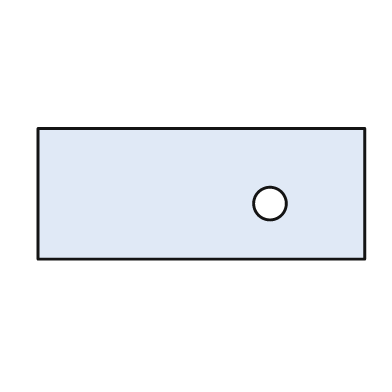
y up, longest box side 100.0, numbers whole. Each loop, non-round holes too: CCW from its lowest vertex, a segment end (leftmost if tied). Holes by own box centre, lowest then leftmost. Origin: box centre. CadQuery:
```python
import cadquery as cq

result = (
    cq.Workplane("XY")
    .moveTo(-50.0, -20.0)
    .lineTo(50.0, -20.0)
    .lineTo(50.0, 20.0)
    .lineTo(-50.0, 20.0)
    .close()
    .moveTo(21.0, -3.0)
    .circle(5.0)
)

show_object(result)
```